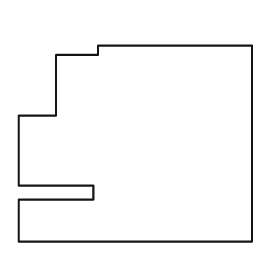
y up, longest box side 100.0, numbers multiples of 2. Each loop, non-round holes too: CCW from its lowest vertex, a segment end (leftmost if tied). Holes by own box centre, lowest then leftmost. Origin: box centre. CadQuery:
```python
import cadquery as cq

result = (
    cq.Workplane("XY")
    .moveTo(-50.0, -42.0)
    .lineTo(50.0, -42.0)
    .lineTo(50.0, 42.0)
    .lineTo(-16.0, 42.0)
    .lineTo(-16.0, 38.0)
    .lineTo(-34.0, 38.0)
    .lineTo(-34.0, 12.0)
    .lineTo(-50.0, 12.0)
    .lineTo(-50.0, -18.0)
    .lineTo(-18.0, -18.0)
    .lineTo(-18.0, -24.0)
    .lineTo(-50.0, -24.0)
    .close()
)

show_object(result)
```